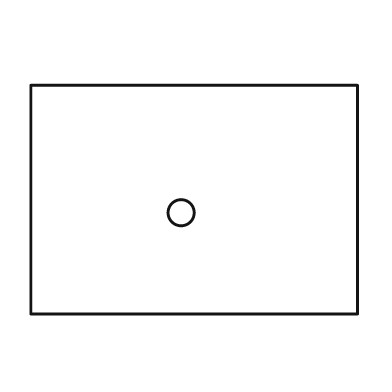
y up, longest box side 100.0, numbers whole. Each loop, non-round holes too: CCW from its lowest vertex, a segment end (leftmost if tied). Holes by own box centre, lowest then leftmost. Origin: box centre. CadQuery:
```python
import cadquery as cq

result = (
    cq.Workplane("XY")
    .moveTo(-50.0, -35.0)
    .lineTo(50.0, -35.0)
    .lineTo(50.0, 35.0)
    .lineTo(-50.0, 35.0)
    .close()
    .moveTo(-4.0, -4.0)
    .circle(4.0)
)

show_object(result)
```